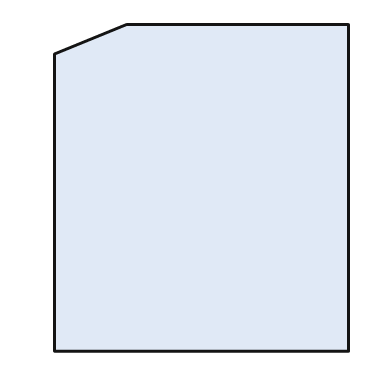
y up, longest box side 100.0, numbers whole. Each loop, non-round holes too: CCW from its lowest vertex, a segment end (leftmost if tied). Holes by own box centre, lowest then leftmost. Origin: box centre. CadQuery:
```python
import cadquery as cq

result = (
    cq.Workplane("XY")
    .moveTo(-45.0, -50.0)
    .lineTo(45.0, -50.0)
    .lineTo(45.0, 50.0)
    .lineTo(-23.0, 50.0)
    .lineTo(-45.0, 41.0)
    .close()
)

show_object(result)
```